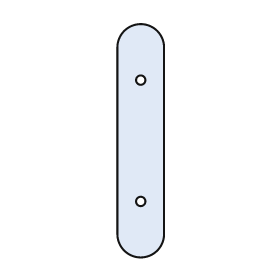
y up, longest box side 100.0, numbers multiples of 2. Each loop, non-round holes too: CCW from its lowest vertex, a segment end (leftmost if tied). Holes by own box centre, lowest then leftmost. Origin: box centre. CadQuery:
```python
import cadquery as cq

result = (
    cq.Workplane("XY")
    .moveTo(-10.0, -40.0)
    .threePointArc((0.0, -50.0), (10.0, -40.0))
    .lineTo(10.0, 40.0)
    .threePointArc((0.0, 50.0), (-10.0, 40.0))
    .close()
    .moveTo(0.0, -26.0)
    .circle(2.0)
    .moveTo(0.0, 26.0)
    .circle(2.0)
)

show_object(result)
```